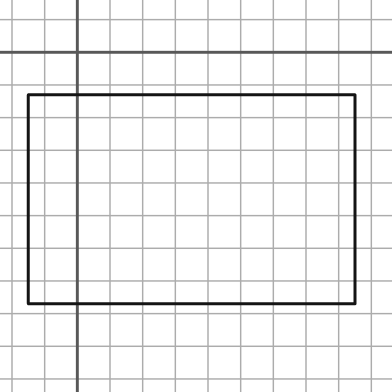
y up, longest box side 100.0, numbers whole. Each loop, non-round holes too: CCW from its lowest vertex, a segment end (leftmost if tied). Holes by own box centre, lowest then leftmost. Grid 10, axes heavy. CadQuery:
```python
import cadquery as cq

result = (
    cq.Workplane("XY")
    .moveTo(-15.0, -77.0)
    .lineTo(85.0, -77.0)
    .lineTo(85.0, -13.0)
    .lineTo(-15.0, -13.0)
    .close()
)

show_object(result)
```